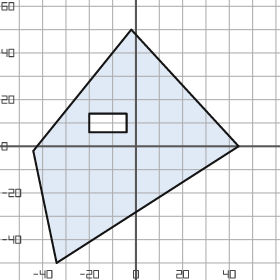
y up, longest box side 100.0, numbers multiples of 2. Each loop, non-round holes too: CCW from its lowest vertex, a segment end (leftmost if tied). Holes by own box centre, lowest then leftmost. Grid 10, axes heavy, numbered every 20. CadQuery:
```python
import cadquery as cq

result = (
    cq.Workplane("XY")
    .moveTo(-34.0, -50.0)
    .lineTo(44.0, 0.0)
    .lineTo(-2.0, 50.0)
    .lineTo(-44.0, -2.0)
    .close()
    .moveTo(-20.0, 6.0)
    .lineTo(-4.0, 6.0)
    .lineTo(-4.0, 14.0)
    .lineTo(-20.0, 14.0)
    .close()
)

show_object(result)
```